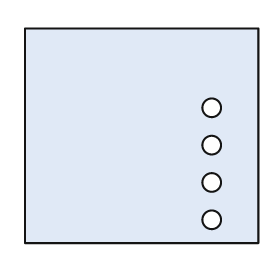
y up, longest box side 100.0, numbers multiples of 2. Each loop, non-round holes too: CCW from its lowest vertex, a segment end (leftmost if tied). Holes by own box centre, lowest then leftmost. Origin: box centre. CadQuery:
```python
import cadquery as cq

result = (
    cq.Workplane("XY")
    .moveTo(-50.0, -46.0)
    .lineTo(50.0, -46.0)
    .lineTo(50.0, 46.0)
    .lineTo(-50.0, 46.0)
    .close()
    .moveTo(30.0, -36.0)
    .circle(4.0)
    .moveTo(30.0, -20.0)
    .circle(4.0)
    .moveTo(30.0, -4.0)
    .circle(4.0)
    .moveTo(30.0, 12.0)
    .circle(4.0)
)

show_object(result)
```